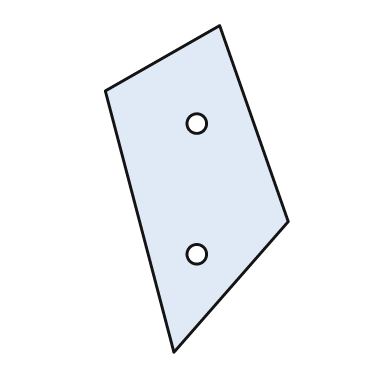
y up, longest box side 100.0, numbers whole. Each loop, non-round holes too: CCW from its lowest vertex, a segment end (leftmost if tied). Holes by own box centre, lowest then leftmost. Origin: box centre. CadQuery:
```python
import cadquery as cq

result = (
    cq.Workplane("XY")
    .moveTo(-7.0, -50.0)
    .lineTo(28.0, -10.0)
    .lineTo(7.0, 50.0)
    .lineTo(-28.0, 30.0)
    .close()
    .moveTo(0.0, -20.0)
    .circle(3.0)
    .moveTo(0.0, 20.0)
    .circle(3.0)
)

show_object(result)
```